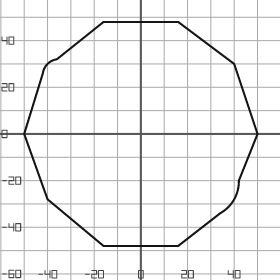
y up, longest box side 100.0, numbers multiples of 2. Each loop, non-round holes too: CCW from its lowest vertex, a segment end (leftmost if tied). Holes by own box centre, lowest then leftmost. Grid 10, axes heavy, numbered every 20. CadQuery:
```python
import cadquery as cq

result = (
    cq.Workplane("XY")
    .moveTo(-16.0, -48.0)
    .lineTo(16.0, -48.0)
    .lineTo(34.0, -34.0)
    .threePointArc((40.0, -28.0), (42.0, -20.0))
    .lineTo(50.0, 0.0)
    .lineTo(40.0, 30.0)
    .lineTo(16.0, 48.0)
    .lineTo(-16.0, 48.0)
    .lineTo(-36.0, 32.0)
    .threePointArc((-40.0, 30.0), (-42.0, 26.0))
    .lineTo(-50.0, 0.0)
    .lineTo(-40.0, -28.0)
    .close()
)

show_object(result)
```